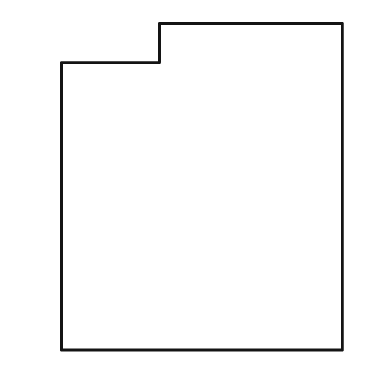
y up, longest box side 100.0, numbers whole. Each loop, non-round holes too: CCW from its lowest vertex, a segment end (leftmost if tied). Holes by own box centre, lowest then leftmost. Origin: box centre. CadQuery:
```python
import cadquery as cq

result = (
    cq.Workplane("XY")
    .moveTo(-43.0, -50.0)
    .lineTo(43.0, -50.0)
    .lineTo(43.0, 50.0)
    .lineTo(-13.0, 50.0)
    .lineTo(-13.0, 38.0)
    .lineTo(-43.0, 38.0)
    .close()
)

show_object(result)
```